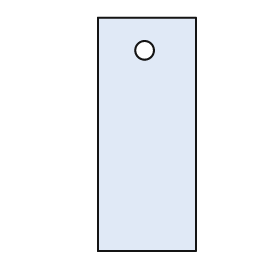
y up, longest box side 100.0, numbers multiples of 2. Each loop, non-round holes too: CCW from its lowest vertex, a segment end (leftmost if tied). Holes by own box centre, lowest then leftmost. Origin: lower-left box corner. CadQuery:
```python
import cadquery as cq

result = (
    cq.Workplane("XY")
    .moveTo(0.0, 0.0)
    .lineTo(42.0, 0.0)
    .lineTo(42.0, 100.0)
    .lineTo(0.0, 100.0)
    .close()
    .moveTo(20.0, 86.0)
    .circle(4.0)
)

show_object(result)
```